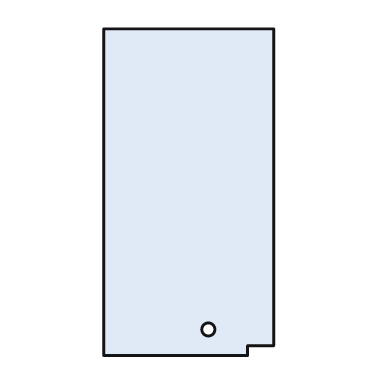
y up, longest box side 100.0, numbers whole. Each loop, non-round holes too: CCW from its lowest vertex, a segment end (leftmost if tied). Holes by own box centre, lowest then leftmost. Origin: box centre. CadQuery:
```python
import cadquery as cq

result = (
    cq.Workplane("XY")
    .moveTo(-26.0, -50.0)
    .lineTo(18.0, -50.0)
    .lineTo(18.0, -47.0)
    .lineTo(26.0, -47.0)
    .lineTo(26.0, 50.0)
    .lineTo(-26.0, 50.0)
    .close()
    .moveTo(6.0, -42.0)
    .circle(2.0)
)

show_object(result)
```